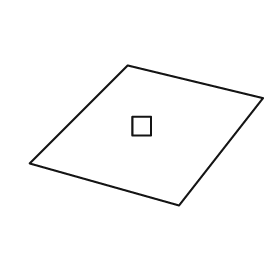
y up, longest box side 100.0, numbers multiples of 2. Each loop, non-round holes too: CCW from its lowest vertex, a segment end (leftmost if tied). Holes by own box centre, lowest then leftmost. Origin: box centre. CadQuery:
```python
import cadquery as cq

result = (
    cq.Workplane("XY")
    .moveTo(14.0, -30.0)
    .lineTo(50.0, 16.0)
    .lineTo(-8.0, 30.0)
    .lineTo(-50.0, -12.0)
    .close()
    .moveTo(-6.0, 0.0)
    .lineTo(2.0, 0.0)
    .lineTo(2.0, 8.0)
    .lineTo(-6.0, 8.0)
    .close()
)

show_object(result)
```